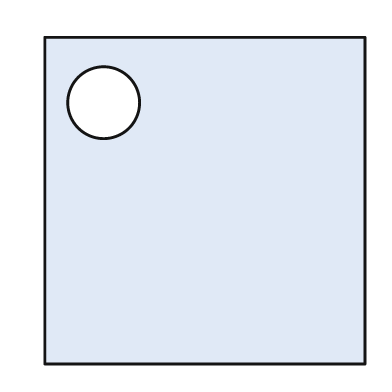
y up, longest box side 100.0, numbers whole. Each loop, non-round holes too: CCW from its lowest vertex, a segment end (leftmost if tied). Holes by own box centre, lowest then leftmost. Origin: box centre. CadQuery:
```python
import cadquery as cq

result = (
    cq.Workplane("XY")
    .moveTo(-49.0, -50.0)
    .lineTo(49.0, -50.0)
    .lineTo(49.0, 50.0)
    .lineTo(-49.0, 50.0)
    .close()
    .moveTo(-31.0, 30.0)
    .circle(11.0)
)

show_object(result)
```